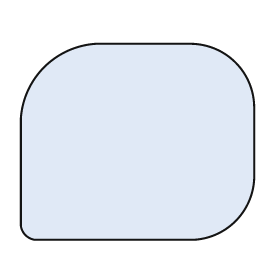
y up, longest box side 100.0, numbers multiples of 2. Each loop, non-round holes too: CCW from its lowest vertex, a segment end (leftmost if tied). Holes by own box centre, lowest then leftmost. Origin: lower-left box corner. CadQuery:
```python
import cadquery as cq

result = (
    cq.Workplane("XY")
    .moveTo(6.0, 0.0)
    .lineTo(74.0, 0.0)
    .threePointArc((92.0, 8.0), (100.0, 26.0))
    .lineTo(100.0, 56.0)
    .threePointArc((92.0, 76.0), (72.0, 84.0))
    .lineTo(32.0, 84.0)
    .threePointArc((10.0, 74.0), (0.0, 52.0))
    .lineTo(0.0, 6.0)
    .threePointArc((2.0, 2.0), (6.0, 0.0))
    .close()
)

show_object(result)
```